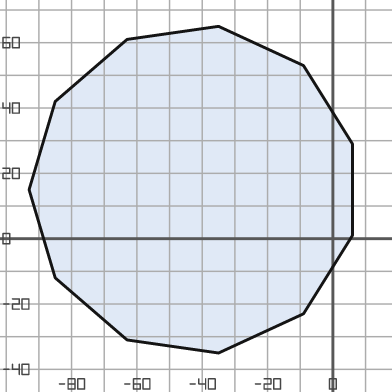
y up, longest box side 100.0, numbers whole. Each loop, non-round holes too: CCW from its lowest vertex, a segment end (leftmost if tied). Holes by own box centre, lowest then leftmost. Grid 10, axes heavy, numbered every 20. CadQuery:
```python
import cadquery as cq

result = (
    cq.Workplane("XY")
    .moveTo(-35.0, -35.0)
    .lineTo(-9.0, -23.0)
    .lineTo(6.0, 1.0)
    .lineTo(6.0, 29.0)
    .lineTo(-9.0, 53.0)
    .lineTo(-35.0, 65.0)
    .lineTo(-63.0, 61.0)
    .lineTo(-85.0, 42.0)
    .lineTo(-93.0, 15.0)
    .lineTo(-85.0, -12.0)
    .lineTo(-63.0, -31.0)
    .close()
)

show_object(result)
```